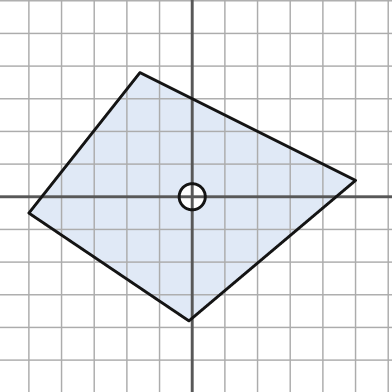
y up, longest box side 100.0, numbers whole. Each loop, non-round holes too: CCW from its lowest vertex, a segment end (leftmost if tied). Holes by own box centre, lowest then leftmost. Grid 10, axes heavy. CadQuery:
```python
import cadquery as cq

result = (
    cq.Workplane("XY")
    .moveTo(-1.0, -38.0)
    .lineTo(50.0, 5.0)
    .lineTo(-16.0, 38.0)
    .lineTo(-50.0, -5.0)
    .close()
    .moveTo(0.0, 0.0)
    .circle(4.0)
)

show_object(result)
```